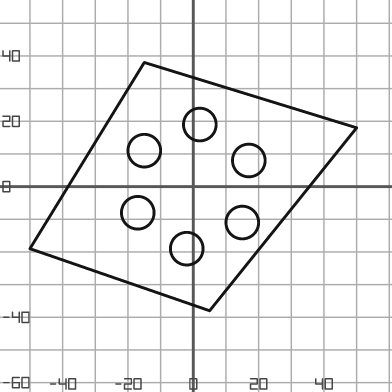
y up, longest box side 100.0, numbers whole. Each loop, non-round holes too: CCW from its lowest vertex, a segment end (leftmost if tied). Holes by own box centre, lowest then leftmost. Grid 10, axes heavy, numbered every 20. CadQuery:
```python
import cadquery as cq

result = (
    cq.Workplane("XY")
    .moveTo(5.0, -38.0)
    .lineTo(50.0, 18.0)
    .lineTo(-15.0, 38.0)
    .lineTo(-50.0, -19.0)
    .close()
    .moveTo(-2.0, -19.0)
    .circle(5.0)
    .moveTo(15.0, -11.0)
    .circle(5.0)
    .moveTo(-17.0, -8.0)
    .circle(5.0)
    .moveTo(17.0, 8.0)
    .circle(5.0)
    .moveTo(-15.0, 11.0)
    .circle(5.0)
    .moveTo(2.0, 19.0)
    .circle(5.0)
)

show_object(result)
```